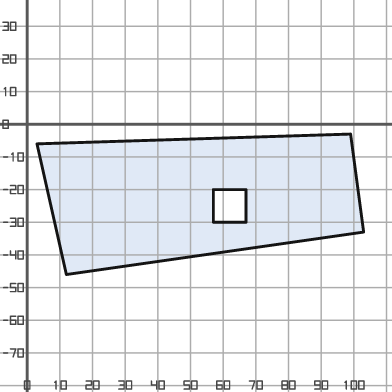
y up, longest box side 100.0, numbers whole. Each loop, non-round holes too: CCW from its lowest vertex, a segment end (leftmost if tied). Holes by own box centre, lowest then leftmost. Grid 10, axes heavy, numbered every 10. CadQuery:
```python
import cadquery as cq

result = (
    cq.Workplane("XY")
    .moveTo(12.0, -46.0)
    .lineTo(103.0, -33.0)
    .lineTo(99.0, -3.0)
    .lineTo(3.0, -6.0)
    .close()
    .moveTo(57.0, -30.0)
    .lineTo(67.0, -30.0)
    .lineTo(67.0, -20.0)
    .lineTo(57.0, -20.0)
    .close()
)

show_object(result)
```